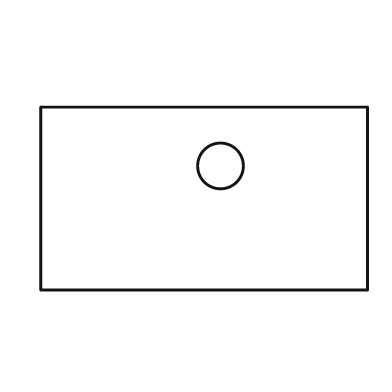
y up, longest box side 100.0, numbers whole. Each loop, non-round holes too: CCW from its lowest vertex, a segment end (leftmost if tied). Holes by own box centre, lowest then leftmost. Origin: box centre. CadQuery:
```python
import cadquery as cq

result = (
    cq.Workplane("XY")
    .moveTo(-50.0, -28.0)
    .lineTo(50.0, -28.0)
    .lineTo(50.0, 28.0)
    .lineTo(-50.0, 28.0)
    .close()
    .moveTo(5.0, 10.0)
    .circle(7.0)
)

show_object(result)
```